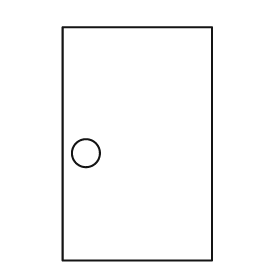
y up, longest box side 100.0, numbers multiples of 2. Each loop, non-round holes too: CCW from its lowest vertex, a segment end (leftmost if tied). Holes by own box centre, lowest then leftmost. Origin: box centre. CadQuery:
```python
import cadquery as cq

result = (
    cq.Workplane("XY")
    .moveTo(-32.0, -50.0)
    .lineTo(32.0, -50.0)
    .lineTo(32.0, 50.0)
    .lineTo(-32.0, 50.0)
    .close()
    .moveTo(-22.0, -4.0)
    .circle(6.0)
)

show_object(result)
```